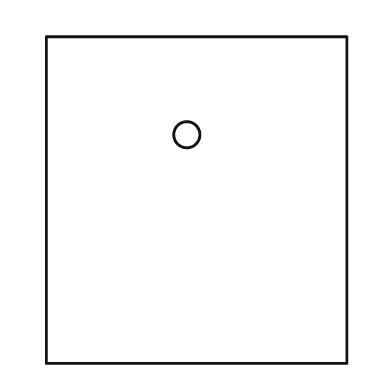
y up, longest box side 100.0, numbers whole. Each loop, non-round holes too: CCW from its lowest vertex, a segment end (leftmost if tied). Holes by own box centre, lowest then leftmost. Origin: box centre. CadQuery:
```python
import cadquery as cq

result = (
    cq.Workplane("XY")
    .moveTo(-46.0, -50.0)
    .lineTo(46.0, -50.0)
    .lineTo(46.0, 50.0)
    .lineTo(-46.0, 50.0)
    .close()
    .moveTo(-3.0, 20.0)
    .circle(4.0)
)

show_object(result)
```